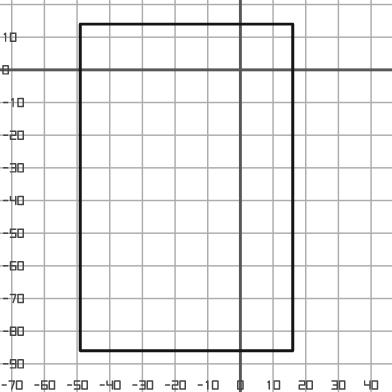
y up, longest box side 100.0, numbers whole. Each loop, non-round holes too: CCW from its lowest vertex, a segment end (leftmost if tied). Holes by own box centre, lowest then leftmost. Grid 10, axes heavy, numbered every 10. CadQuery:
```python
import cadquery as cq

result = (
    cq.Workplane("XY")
    .moveTo(-49.0, -86.0)
    .lineTo(16.0, -86.0)
    .lineTo(16.0, 14.0)
    .lineTo(-49.0, 14.0)
    .close()
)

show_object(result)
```